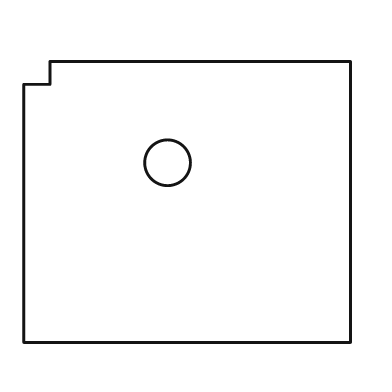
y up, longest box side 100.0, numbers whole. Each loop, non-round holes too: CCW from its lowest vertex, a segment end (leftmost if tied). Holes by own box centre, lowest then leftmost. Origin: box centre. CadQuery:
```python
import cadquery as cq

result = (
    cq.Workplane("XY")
    .moveTo(-50.0, -43.0)
    .lineTo(50.0, -43.0)
    .lineTo(50.0, 43.0)
    .lineTo(-42.0, 43.0)
    .lineTo(-42.0, 36.0)
    .lineTo(-50.0, 36.0)
    .close()
    .moveTo(-6.0, 12.0)
    .circle(7.0)
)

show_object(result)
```